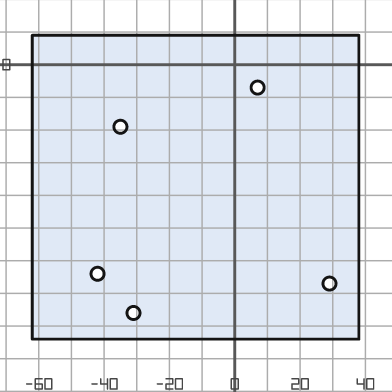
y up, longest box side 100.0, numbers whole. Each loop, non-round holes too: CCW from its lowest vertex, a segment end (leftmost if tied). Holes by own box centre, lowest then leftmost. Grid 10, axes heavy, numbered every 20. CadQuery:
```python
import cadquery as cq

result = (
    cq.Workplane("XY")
    .moveTo(-62.0, -84.0)
    .lineTo(38.0, -84.0)
    .lineTo(38.0, 9.0)
    .lineTo(-62.0, 9.0)
    .close()
    .moveTo(-31.0, -76.0)
    .circle(2.0)
    .moveTo(29.0, -67.0)
    .circle(2.0)
    .moveTo(-42.0, -64.0)
    .circle(2.0)
    .moveTo(-35.0, -19.0)
    .circle(2.0)
    .moveTo(7.0, -7.0)
    .circle(2.0)
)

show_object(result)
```